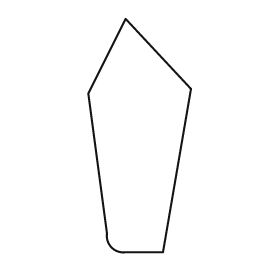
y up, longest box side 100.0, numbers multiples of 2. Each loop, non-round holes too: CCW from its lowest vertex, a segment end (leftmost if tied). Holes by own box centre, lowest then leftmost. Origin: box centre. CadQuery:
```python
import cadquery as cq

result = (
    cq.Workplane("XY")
    .moveTo(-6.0, -50.0)
    .lineTo(10.0, -50.0)
    .lineTo(22.0, 20.0)
    .lineTo(-6.0, 50.0)
    .lineTo(-22.0, 18.0)
    .lineTo(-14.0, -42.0)
    .threePointArc((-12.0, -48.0), (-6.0, -50.0))
    .close()
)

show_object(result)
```